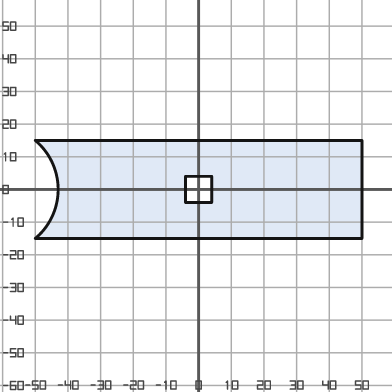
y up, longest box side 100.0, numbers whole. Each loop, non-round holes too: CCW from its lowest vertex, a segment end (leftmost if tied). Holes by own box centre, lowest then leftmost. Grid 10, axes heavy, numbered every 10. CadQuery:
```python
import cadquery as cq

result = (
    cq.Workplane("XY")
    .moveTo(-50.0, -15.0)
    .lineTo(50.0, -15.0)
    .lineTo(50.0, 15.0)
    .lineTo(-50.0, 15.0)
    .threePointArc((-43.0, 0.0), (-50.0, -15.0))
    .close()
    .moveTo(-4.0, -4.0)
    .lineTo(4.0, -4.0)
    .lineTo(4.0, 4.0)
    .lineTo(-4.0, 4.0)
    .close()
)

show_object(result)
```